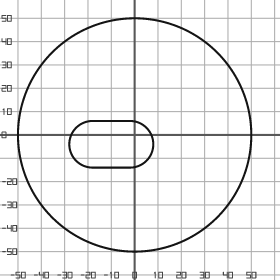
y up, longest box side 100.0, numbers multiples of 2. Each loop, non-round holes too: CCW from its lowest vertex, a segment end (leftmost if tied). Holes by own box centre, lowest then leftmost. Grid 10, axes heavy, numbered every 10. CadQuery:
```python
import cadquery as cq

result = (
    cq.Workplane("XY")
    .moveTo(0.0, 0.0)
    .circle(50.0)
    .moveTo(-18.0, -14.0)
    .lineTo(-2.0, -14.0)
    .threePointArc((8.0, -4.0), (-2.0, 6.0))
    .lineTo(-18.0, 6.0)
    .threePointArc((-28.0, -4.0), (-18.0, -14.0))
    .close()
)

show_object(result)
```